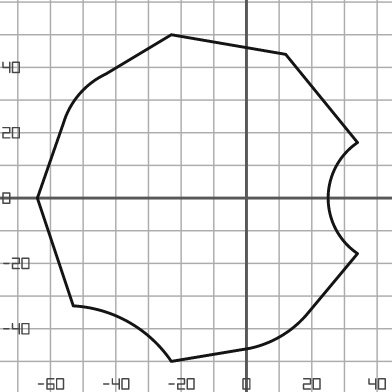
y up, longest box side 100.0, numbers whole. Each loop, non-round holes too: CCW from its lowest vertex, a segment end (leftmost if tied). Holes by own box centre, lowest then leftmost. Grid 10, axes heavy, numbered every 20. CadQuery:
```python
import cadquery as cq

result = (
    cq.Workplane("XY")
    .moveTo(-23.0, -50.0)
    .lineTo(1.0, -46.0)
    .threePointArc((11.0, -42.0), (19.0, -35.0))
    .lineTo(34.0, -17.0)
    .threePointArc((25.0, 0.0), (34.0, 17.0))
    .lineTo(12.0, 44.0)
    .lineTo(-23.0, 50.0)
    .lineTo(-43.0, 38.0)
    .threePointArc((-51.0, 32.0), (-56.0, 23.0))
    .lineTo(-64.0, 0.0)
    .lineTo(-53.0, -33.0)
    .threePointArc((-36.0, -38.0), (-23.0, -50.0))
    .close()
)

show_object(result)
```